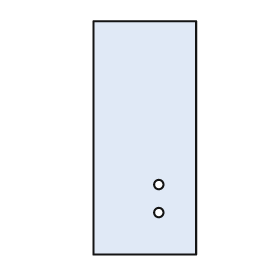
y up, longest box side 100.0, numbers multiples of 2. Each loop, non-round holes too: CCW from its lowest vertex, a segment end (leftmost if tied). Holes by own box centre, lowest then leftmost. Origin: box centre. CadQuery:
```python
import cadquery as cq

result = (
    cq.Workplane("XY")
    .moveTo(-22.0, -50.0)
    .lineTo(22.0, -50.0)
    .lineTo(22.0, 50.0)
    .lineTo(-22.0, 50.0)
    .close()
    .moveTo(6.0, -32.0)
    .circle(2.0)
    .moveTo(6.0, -20.0)
    .circle(2.0)
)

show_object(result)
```